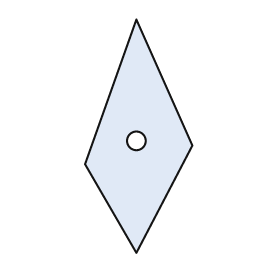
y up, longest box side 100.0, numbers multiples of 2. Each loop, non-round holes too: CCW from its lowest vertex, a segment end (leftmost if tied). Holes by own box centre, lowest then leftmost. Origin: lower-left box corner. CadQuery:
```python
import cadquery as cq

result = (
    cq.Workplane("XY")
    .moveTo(22.0, 0.0)
    .lineTo(46.0, 46.0)
    .lineTo(22.0, 100.0)
    .lineTo(0.0, 38.0)
    .close()
    .moveTo(22.0, 48.0)
    .circle(4.0)
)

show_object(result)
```